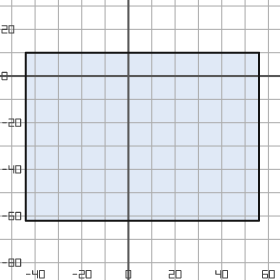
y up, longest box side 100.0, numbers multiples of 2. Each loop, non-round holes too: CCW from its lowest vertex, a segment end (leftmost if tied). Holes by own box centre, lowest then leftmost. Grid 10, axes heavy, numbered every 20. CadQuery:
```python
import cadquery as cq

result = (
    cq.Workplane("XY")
    .moveTo(-44.0, -62.0)
    .lineTo(56.0, -62.0)
    .lineTo(56.0, 10.0)
    .lineTo(-44.0, 10.0)
    .close()
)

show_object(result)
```